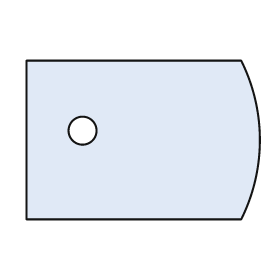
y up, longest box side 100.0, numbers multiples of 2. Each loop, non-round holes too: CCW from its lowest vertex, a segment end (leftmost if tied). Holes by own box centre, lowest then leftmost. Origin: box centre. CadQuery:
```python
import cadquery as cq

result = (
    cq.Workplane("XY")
    .moveTo(-50.0, -34.0)
    .lineTo(42.0, -34.0)
    .threePointArc((50.0, 0.0), (42.0, 34.0))
    .lineTo(-50.0, 34.0)
    .close()
    .moveTo(-26.0, 4.0)
    .circle(6.0)
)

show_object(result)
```